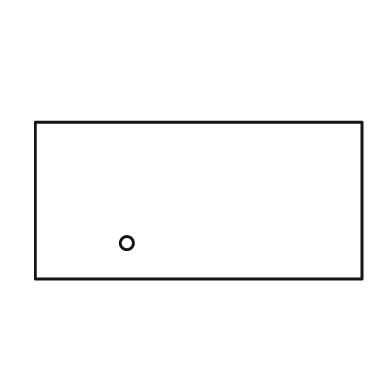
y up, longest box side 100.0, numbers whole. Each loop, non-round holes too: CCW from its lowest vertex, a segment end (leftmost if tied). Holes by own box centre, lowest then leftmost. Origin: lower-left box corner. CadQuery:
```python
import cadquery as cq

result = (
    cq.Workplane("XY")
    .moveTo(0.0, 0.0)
    .lineTo(100.0, 0.0)
    .lineTo(100.0, 48.0)
    .lineTo(0.0, 48.0)
    .close()
    .moveTo(28.0, 11.0)
    .circle(2.0)
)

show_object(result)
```